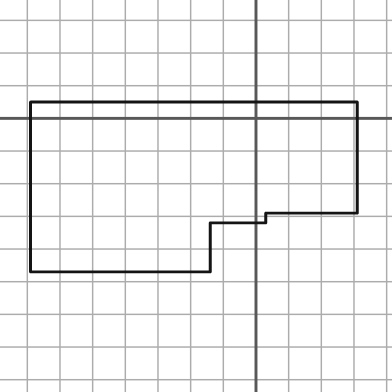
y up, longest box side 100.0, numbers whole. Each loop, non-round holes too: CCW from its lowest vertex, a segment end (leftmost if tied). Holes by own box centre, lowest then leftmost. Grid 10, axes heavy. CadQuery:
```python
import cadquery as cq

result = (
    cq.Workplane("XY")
    .moveTo(-69.0, -47.0)
    .lineTo(-14.0, -47.0)
    .lineTo(-14.0, -32.0)
    .lineTo(3.0, -32.0)
    .lineTo(3.0, -29.0)
    .lineTo(31.0, -29.0)
    .lineTo(31.0, 5.0)
    .lineTo(-69.0, 5.0)
    .close()
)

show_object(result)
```